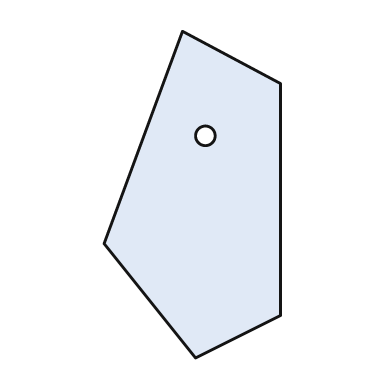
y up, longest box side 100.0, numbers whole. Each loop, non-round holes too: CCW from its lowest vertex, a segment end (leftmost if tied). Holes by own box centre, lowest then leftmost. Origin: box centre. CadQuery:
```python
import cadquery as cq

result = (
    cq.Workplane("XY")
    .moveTo(1.0, -50.0)
    .lineTo(27.0, -37.0)
    .lineTo(27.0, 34.0)
    .lineTo(-3.0, 50.0)
    .lineTo(-27.0, -15.0)
    .close()
    .moveTo(4.0, 18.0)
    .circle(3.0)
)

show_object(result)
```